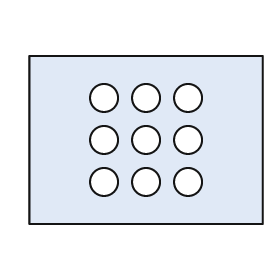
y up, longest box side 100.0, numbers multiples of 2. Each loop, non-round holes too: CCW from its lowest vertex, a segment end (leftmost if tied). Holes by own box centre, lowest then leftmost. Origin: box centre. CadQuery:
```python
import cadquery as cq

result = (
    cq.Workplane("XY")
    .moveTo(-50.0, -36.0)
    .lineTo(50.0, -36.0)
    .lineTo(50.0, 36.0)
    .lineTo(-50.0, 36.0)
    .close()
    .moveTo(-18.0, -18.0)
    .circle(6.0)
    .moveTo(0.0, -18.0)
    .circle(6.0)
    .moveTo(18.0, -18.0)
    .circle(6.0)
    .moveTo(-18.0, 0.0)
    .circle(6.0)
    .moveTo(0.0, 0.0)
    .circle(6.0)
    .moveTo(18.0, 0.0)
    .circle(6.0)
    .moveTo(-18.0, 18.0)
    .circle(6.0)
    .moveTo(0.0, 18.0)
    .circle(6.0)
    .moveTo(18.0, 18.0)
    .circle(6.0)
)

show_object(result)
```